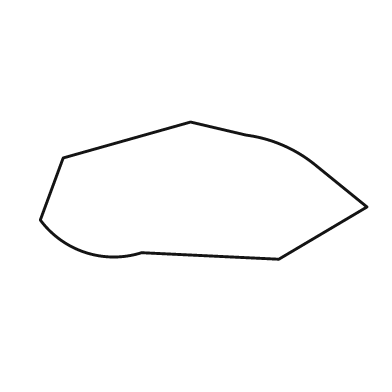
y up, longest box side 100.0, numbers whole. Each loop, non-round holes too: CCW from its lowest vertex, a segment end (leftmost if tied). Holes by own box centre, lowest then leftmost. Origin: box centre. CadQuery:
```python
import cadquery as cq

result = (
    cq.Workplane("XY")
    .moveTo(23.0, -21.0)
    .lineTo(50.0, -5.0)
    .lineTo(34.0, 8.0)
    .threePointArc((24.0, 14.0), (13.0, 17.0))
    .lineTo(-4.0, 21.0)
    .lineTo(-43.0, 10.0)
    .lineTo(-50.0, -9.0)
    .threePointArc((-36.0, -19.0), (-19.0, -19.0))
    .close()
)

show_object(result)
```